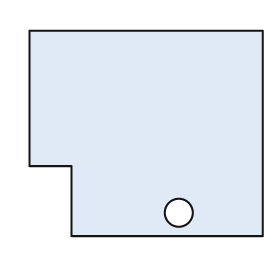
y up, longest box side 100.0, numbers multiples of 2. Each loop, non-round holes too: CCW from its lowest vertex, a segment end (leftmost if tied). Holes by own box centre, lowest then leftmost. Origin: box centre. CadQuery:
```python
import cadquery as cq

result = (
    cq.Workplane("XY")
    .moveTo(-32.0, -44.0)
    .lineTo(50.0, -44.0)
    .lineTo(50.0, 44.0)
    .lineTo(-50.0, 44.0)
    .lineTo(-50.0, -14.0)
    .lineTo(-32.0, -14.0)
    .close()
    .moveTo(14.0, -34.0)
    .circle(6.0)
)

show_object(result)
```